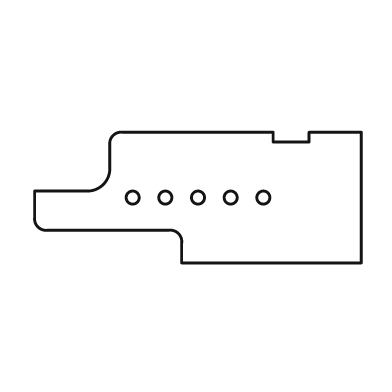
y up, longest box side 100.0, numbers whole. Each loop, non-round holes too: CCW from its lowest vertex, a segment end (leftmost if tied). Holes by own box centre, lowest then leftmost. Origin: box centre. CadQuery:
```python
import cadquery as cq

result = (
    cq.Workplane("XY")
    .moveTo(-5.0, -20.0)
    .lineTo(50.0, -20.0)
    .lineTo(50.0, 20.0)
    .lineTo(34.0, 20.0)
    .lineTo(34.0, 17.0)
    .lineTo(23.0, 17.0)
    .lineTo(23.0, 20.0)
    .lineTo(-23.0, 20.0)
    .threePointArc((-26.0, 19.0), (-27.0, 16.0))
    .lineTo(-27.0, 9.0)
    .threePointArc((-29.0, 4.0), (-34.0, 2.0))
    .lineTo(-50.0, 2.0)
    .lineTo(-50.0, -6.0)
    .threePointArc((-49.0, -9.0), (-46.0, -10.0))
    .lineTo(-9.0, -10.0)
    .threePointArc((-6.0, -11.0), (-5.0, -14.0))
    .close()
    .moveTo(-20.0, 0.0)
    .circle(2.0)
    .moveTo(-10.0, 0.0)
    .circle(2.0)
    .moveTo(0.0, 0.0)
    .circle(2.0)
    .moveTo(10.0, 0.0)
    .circle(2.0)
    .moveTo(20.0, 0.0)
    .circle(2.0)
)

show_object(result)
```